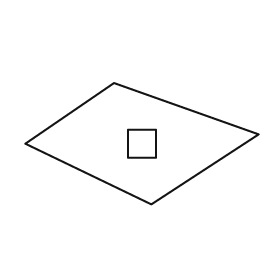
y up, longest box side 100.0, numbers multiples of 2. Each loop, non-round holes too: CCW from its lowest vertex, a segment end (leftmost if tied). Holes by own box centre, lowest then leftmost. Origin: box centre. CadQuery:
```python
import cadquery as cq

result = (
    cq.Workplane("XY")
    .moveTo(4.0, -26.0)
    .lineTo(50.0, 4.0)
    .lineTo(-12.0, 26.0)
    .lineTo(-50.0, 0.0)
    .close()
    .moveTo(-6.0, -6.0)
    .lineTo(6.0, -6.0)
    .lineTo(6.0, 6.0)
    .lineTo(-6.0, 6.0)
    .close()
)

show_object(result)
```